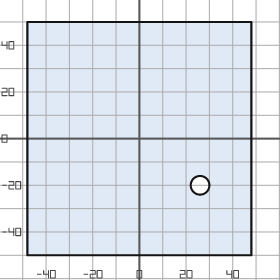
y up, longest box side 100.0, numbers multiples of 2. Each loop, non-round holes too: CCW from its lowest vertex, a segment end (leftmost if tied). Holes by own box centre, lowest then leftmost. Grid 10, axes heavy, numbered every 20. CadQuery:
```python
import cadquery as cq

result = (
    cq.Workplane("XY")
    .moveTo(-48.0, -50.0)
    .lineTo(48.0, -50.0)
    .lineTo(48.0, 50.0)
    .lineTo(-48.0, 50.0)
    .close()
    .moveTo(26.0, -20.0)
    .circle(4.0)
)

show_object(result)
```